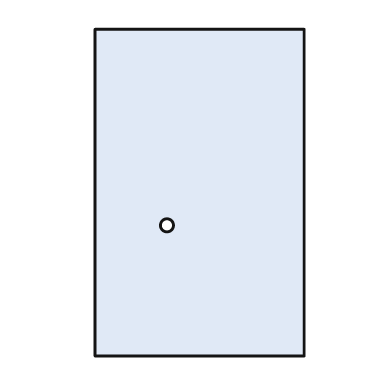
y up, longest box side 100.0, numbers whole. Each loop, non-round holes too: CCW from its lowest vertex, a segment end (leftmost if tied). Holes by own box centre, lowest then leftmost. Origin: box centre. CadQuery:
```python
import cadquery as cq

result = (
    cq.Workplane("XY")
    .moveTo(-32.0, -50.0)
    .lineTo(32.0, -50.0)
    .lineTo(32.0, 50.0)
    .lineTo(-32.0, 50.0)
    .close()
    .moveTo(-10.0, -10.0)
    .circle(2.0)
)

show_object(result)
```